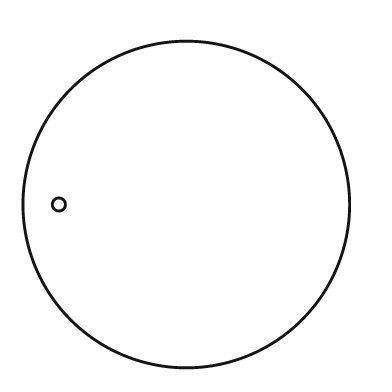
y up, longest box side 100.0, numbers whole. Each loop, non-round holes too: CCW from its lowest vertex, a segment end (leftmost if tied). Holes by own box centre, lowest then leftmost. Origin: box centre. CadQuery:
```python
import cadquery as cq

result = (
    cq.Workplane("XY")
    .moveTo(0.0, 0.0)
    .circle(50.0)
    .moveTo(-39.0, 0.0)
    .circle(2.0)
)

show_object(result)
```